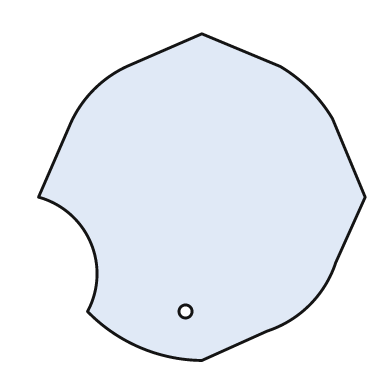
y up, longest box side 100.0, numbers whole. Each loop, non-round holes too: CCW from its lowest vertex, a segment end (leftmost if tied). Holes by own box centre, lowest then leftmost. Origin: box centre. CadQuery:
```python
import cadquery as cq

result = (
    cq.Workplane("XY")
    .moveTo(0.0, -50.0)
    .lineTo(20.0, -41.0)
    .threePointArc((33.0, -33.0), (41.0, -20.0))
    .lineTo(50.0, 0.0)
    .lineTo(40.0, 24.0)
    .threePointArc((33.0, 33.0), (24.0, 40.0))
    .lineTo(0.0, 50.0)
    .lineTo(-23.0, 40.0)
    .threePointArc((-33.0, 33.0), (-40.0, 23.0))
    .lineTo(-50.0, 0.0)
    .threePointArc((-34.0, -14.0), (-35.0, -35.0))
    .threePointArc((-19.0, -46.0), (0.0, -50.0))
    .close()
    .moveTo(-5.0, -35.0)
    .circle(2.0)
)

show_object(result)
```